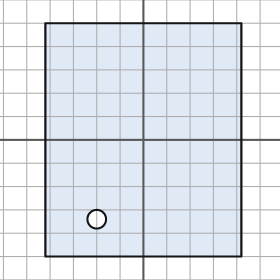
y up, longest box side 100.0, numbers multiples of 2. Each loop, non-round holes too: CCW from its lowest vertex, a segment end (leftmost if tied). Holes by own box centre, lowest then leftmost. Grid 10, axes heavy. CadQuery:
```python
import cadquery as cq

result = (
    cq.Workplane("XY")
    .moveTo(-42.0, -50.0)
    .lineTo(42.0, -50.0)
    .lineTo(42.0, 50.0)
    .lineTo(-42.0, 50.0)
    .close()
    .moveTo(-20.0, -34.0)
    .circle(4.0)
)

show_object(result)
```